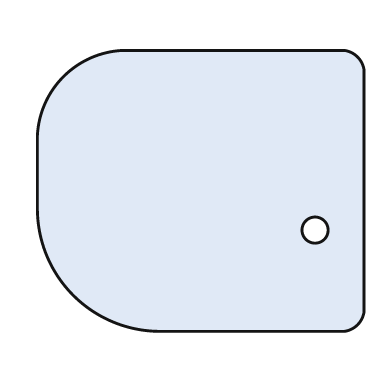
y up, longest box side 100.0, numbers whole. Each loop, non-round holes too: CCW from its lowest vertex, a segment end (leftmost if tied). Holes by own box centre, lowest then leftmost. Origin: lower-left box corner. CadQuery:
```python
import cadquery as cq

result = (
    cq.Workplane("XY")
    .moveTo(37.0, 0.0)
    .lineTo(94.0, 0.0)
    .threePointArc((98.0, 2.0), (100.0, 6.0))
    .lineTo(100.0, 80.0)
    .threePointArc((98.0, 84.0), (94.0, 86.0))
    .lineTo(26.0, 86.0)
    .threePointArc((8.0, 78.0), (0.0, 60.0))
    .lineTo(0.0, 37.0)
    .threePointArc((11.0, 11.0), (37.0, 0.0))
    .close()
    .moveTo(85.0, 31.0)
    .circle(4.0)
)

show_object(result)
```